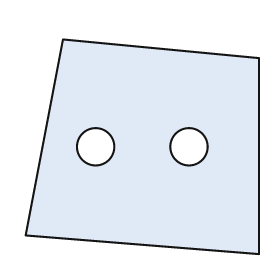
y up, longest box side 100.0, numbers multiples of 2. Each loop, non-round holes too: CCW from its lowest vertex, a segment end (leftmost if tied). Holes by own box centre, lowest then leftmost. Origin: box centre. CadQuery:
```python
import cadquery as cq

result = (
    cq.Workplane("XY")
    .moveTo(50.0, -46.0)
    .lineTo(50.0, 38.0)
    .lineTo(-34.0, 46.0)
    .lineTo(-50.0, -38.0)
    .close()
    .moveTo(-20.0, 0.0)
    .circle(8.0)
    .moveTo(20.0, 0.0)
    .circle(8.0)
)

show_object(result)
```